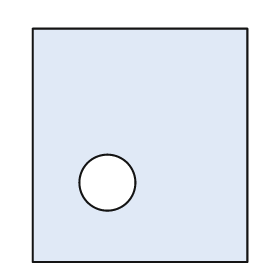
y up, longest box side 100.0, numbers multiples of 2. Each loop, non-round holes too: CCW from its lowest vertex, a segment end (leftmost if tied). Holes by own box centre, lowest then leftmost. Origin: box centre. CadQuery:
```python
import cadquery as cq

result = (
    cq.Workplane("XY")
    .moveTo(-46.0, -50.0)
    .lineTo(46.0, -50.0)
    .lineTo(46.0, 50.0)
    .lineTo(-46.0, 50.0)
    .close()
    .moveTo(-14.0, -16.0)
    .circle(12.0)
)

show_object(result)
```